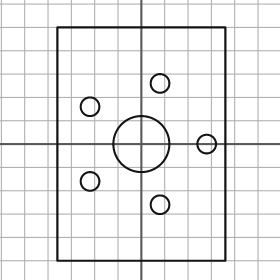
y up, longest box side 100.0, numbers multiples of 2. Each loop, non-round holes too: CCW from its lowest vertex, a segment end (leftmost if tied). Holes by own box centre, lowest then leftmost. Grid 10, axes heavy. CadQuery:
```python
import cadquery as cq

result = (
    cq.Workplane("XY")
    .moveTo(-36.0, -50.0)
    .lineTo(36.0, -50.0)
    .lineTo(36.0, 50.0)
    .lineTo(-36.0, 50.0)
    .close()
    .moveTo(8.0, -26.0)
    .circle(4.0)
    .moveTo(-22.0, -16.0)
    .circle(4.0)
    .moveTo(0.0, 0.0)
    .circle(12.0)
    .moveTo(28.0, 0.0)
    .circle(4.0)
    .moveTo(-22.0, 16.0)
    .circle(4.0)
    .moveTo(8.0, 26.0)
    .circle(4.0)
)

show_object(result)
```